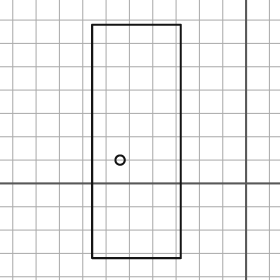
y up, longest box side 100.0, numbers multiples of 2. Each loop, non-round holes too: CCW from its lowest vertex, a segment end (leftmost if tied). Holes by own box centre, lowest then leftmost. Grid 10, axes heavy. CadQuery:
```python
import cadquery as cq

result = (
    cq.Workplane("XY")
    .moveTo(-66.0, -32.0)
    .lineTo(-28.0, -32.0)
    .lineTo(-28.0, 68.0)
    .lineTo(-66.0, 68.0)
    .close()
    .moveTo(-54.0, 10.0)
    .circle(2.0)
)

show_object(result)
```